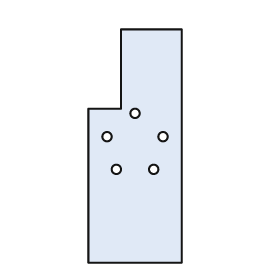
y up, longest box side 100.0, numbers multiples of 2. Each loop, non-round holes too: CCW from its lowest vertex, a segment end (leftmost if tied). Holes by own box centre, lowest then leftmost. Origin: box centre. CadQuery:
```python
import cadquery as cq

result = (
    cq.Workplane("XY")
    .moveTo(-20.0, -50.0)
    .lineTo(20.0, -50.0)
    .lineTo(20.0, 50.0)
    .lineTo(-6.0, 50.0)
    .lineTo(-6.0, 16.0)
    .lineTo(-20.0, 16.0)
    .close()
    .moveTo(-8.0, -10.0)
    .circle(2.0)
    .moveTo(8.0, -10.0)
    .circle(2.0)
    .moveTo(-12.0, 4.0)
    .circle(2.0)
    .moveTo(12.0, 4.0)
    .circle(2.0)
    .moveTo(0.0, 14.0)
    .circle(2.0)
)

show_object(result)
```